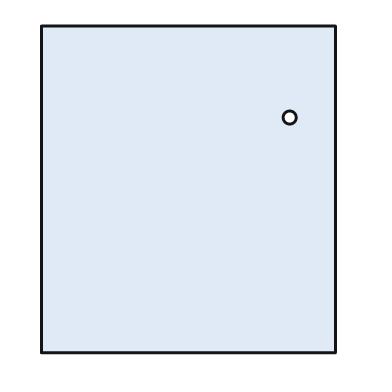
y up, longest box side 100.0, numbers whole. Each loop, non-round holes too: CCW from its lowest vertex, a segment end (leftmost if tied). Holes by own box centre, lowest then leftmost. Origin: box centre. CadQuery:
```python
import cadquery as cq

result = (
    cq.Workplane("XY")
    .moveTo(-45.0, -50.0)
    .lineTo(45.0, -50.0)
    .lineTo(45.0, 50.0)
    .lineTo(-45.0, 50.0)
    .close()
    .moveTo(31.0, 22.0)
    .circle(2.0)
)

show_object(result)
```